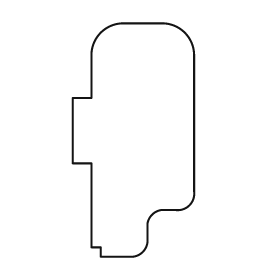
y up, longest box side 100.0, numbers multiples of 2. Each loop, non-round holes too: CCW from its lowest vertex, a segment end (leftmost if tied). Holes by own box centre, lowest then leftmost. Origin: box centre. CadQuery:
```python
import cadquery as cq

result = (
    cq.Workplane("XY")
    .moveTo(-14.0, -50.0)
    .lineTo(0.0, -50.0)
    .threePointArc((4.0, -48.0), (6.0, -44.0))
    .lineTo(6.0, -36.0)
    .threePointArc((8.0, -32.0), (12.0, -30.0))
    .lineTo(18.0, -30.0)
    .threePointArc((24.0, -28.0), (26.0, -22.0))
    .lineTo(26.0, 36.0)
    .threePointArc((22.0, 46.0), (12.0, 50.0))
    .lineTo(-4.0, 50.0)
    .threePointArc((-14.0, 46.0), (-18.0, 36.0))
    .lineTo(-18.0, 18.0)
    .lineTo(-26.0, 18.0)
    .lineTo(-26.0, -10.0)
    .lineTo(-18.0, -10.0)
    .lineTo(-18.0, -46.0)
    .lineTo(-14.0, -46.0)
    .close()
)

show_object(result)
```